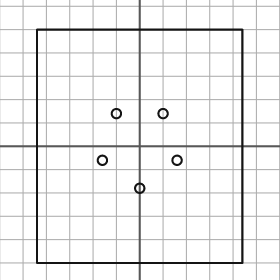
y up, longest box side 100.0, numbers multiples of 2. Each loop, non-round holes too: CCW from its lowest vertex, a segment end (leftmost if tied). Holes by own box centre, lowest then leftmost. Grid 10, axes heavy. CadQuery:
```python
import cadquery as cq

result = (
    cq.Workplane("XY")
    .moveTo(-44.0, -50.0)
    .lineTo(44.0, -50.0)
    .lineTo(44.0, 50.0)
    .lineTo(-44.0, 50.0)
    .close()
    .moveTo(0.0, -18.0)
    .circle(2.0)
    .moveTo(-16.0, -6.0)
    .circle(2.0)
    .moveTo(16.0, -6.0)
    .circle(2.0)
    .moveTo(-10.0, 14.0)
    .circle(2.0)
    .moveTo(10.0, 14.0)
    .circle(2.0)
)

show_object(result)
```